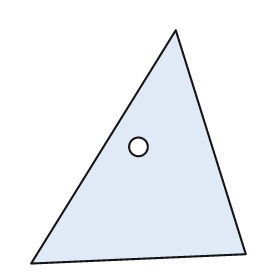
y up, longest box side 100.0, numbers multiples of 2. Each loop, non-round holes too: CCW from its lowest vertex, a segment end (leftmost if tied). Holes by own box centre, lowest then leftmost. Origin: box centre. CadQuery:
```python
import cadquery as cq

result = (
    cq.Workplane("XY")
    .moveTo(-46.0, -50.0)
    .lineTo(46.0, -46.0)
    .lineTo(16.0, 50.0)
    .close()
    .moveTo(0.0, 0.0)
    .circle(4.0)
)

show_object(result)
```